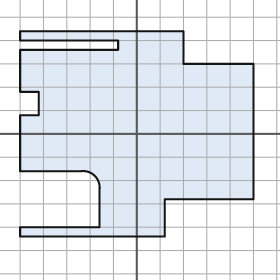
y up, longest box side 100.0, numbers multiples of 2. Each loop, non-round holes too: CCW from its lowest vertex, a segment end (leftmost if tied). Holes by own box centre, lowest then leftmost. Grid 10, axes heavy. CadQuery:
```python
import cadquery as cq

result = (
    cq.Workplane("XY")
    .moveTo(-50.0, -44.0)
    .lineTo(12.0, -44.0)
    .lineTo(12.0, -28.0)
    .lineTo(50.0, -28.0)
    .lineTo(50.0, 30.0)
    .lineTo(20.0, 30.0)
    .lineTo(20.0, 44.0)
    .lineTo(-50.0, 44.0)
    .lineTo(-50.0, 40.0)
    .lineTo(-8.0, 40.0)
    .lineTo(-8.0, 36.0)
    .lineTo(-50.0, 36.0)
    .lineTo(-50.0, 18.0)
    .lineTo(-42.0, 18.0)
    .lineTo(-42.0, 8.0)
    .lineTo(-50.0, 8.0)
    .lineTo(-50.0, -16.0)
    .lineTo(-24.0, -16.0)
    .threePointArc((-18.0, -18.0), (-16.0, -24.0))
    .lineTo(-16.0, -40.0)
    .lineTo(-50.0, -40.0)
    .close()
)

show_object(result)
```